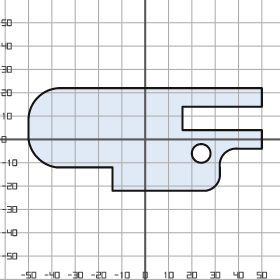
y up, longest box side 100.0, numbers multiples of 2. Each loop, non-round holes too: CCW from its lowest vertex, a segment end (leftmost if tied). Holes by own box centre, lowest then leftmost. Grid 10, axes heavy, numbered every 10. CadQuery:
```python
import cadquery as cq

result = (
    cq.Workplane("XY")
    .moveTo(-14.0, -22.0)
    .lineTo(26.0, -22.0)
    .threePointArc((30.0, -20.0), (32.0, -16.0))
    .lineTo(32.0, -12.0)
    .threePointArc((34.0, -6.0), (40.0, -4.0))
    .lineTo(50.0, -4.0)
    .lineTo(50.0, 4.0)
    .lineTo(16.0, 4.0)
    .lineTo(16.0, 14.0)
    .lineTo(50.0, 14.0)
    .lineTo(50.0, 22.0)
    .lineTo(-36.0, 22.0)
    .threePointArc((-46.0, 18.0), (-50.0, 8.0))
    .lineTo(-50.0, 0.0)
    .threePointArc((-46.0, -8.0), (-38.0, -12.0))
    .lineTo(-14.0, -12.0)
    .close()
    .moveTo(24.0, -6.0)
    .circle(4.0)
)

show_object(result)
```